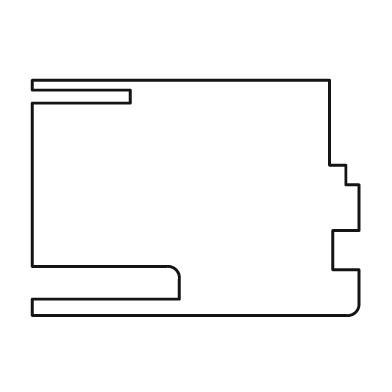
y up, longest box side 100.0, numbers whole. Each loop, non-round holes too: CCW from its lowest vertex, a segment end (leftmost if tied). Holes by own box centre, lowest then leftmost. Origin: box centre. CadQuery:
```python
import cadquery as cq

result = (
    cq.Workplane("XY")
    .moveTo(-50.0, -36.0)
    .lineTo(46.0, -36.0)
    .threePointArc((49.0, -35.0), (50.0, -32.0))
    .lineTo(50.0, -22.0)
    .lineTo(42.0, -22.0)
    .lineTo(42.0, -10.0)
    .lineTo(50.0, -10.0)
    .lineTo(50.0, 4.0)
    .lineTo(46.0, 4.0)
    .lineTo(46.0, 10.0)
    .lineTo(41.0, 10.0)
    .lineTo(41.0, 36.0)
    .lineTo(-50.0, 36.0)
    .lineTo(-50.0, 33.0)
    .lineTo(-20.0, 33.0)
    .lineTo(-20.0, 29.0)
    .lineTo(-50.0, 29.0)
    .lineTo(-50.0, -21.0)
    .lineTo(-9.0, -21.0)
    .threePointArc((-6.0, -22.0), (-5.0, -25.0))
    .lineTo(-5.0, -31.0)
    .lineTo(-50.0, -31.0)
    .close()
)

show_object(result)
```